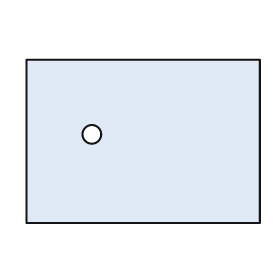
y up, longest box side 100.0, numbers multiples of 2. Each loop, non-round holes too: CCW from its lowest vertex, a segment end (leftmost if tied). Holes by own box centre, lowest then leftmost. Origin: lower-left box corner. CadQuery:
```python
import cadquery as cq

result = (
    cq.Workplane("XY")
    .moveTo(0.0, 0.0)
    .lineTo(100.0, 0.0)
    .lineTo(100.0, 70.0)
    .lineTo(0.0, 70.0)
    .close()
    .moveTo(28.0, 38.0)
    .circle(4.0)
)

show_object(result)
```